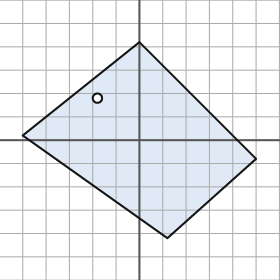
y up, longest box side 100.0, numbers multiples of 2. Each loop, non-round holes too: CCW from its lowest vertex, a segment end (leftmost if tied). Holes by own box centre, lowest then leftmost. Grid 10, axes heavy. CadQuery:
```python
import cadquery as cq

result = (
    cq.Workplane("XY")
    .moveTo(12.0, -42.0)
    .lineTo(50.0, -8.0)
    .lineTo(0.0, 42.0)
    .lineTo(-50.0, 2.0)
    .close()
    .moveTo(-18.0, 18.0)
    .circle(2.0)
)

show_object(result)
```